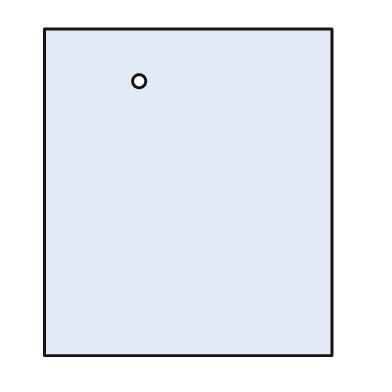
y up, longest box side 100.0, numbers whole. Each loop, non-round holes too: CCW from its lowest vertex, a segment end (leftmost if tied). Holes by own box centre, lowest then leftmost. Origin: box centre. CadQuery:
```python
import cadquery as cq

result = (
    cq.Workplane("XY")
    .moveTo(-44.0, -50.0)
    .lineTo(44.0, -50.0)
    .lineTo(44.0, 50.0)
    .lineTo(-44.0, 50.0)
    .close()
    .moveTo(-15.0, 34.0)
    .circle(2.0)
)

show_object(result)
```